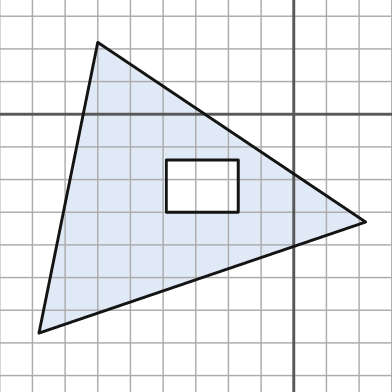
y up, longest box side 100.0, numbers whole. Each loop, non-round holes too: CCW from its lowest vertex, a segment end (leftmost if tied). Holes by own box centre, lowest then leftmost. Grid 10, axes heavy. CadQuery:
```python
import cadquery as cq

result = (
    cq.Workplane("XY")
    .moveTo(-78.0, -67.0)
    .lineTo(22.0, -33.0)
    .lineTo(-60.0, 22.0)
    .close()
    .moveTo(-39.0, -30.0)
    .lineTo(-17.0, -30.0)
    .lineTo(-17.0, -14.0)
    .lineTo(-39.0, -14.0)
    .close()
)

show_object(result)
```